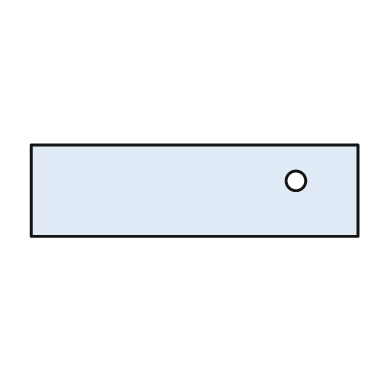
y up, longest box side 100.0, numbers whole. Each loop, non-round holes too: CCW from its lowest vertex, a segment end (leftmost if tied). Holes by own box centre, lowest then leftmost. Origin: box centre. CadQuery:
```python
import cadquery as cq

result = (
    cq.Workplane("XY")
    .moveTo(-50.0, -14.0)
    .lineTo(50.0, -14.0)
    .lineTo(50.0, 14.0)
    .lineTo(-50.0, 14.0)
    .close()
    .moveTo(31.0, 3.0)
    .circle(3.0)
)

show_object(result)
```